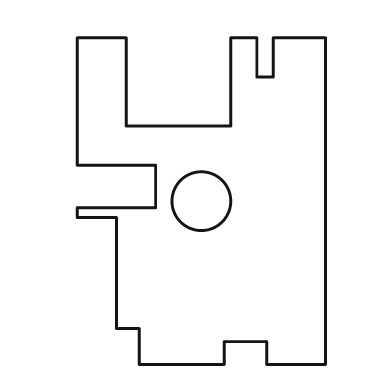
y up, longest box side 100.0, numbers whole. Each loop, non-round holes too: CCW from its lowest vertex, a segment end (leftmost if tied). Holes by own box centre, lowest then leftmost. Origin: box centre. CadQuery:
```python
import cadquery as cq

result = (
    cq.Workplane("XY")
    .moveTo(-19.0, -50.0)
    .lineTo(7.0, -50.0)
    .lineTo(7.0, -43.0)
    .lineTo(20.0, -43.0)
    .lineTo(20.0, -50.0)
    .lineTo(38.0, -50.0)
    .lineTo(38.0, 50.0)
    .lineTo(22.0, 50.0)
    .lineTo(22.0, 38.0)
    .lineTo(17.0, 38.0)
    .lineTo(17.0, 50.0)
    .lineTo(9.0, 50.0)
    .lineTo(9.0, 23.0)
    .lineTo(-23.0, 23.0)
    .lineTo(-23.0, 50.0)
    .lineTo(-38.0, 50.0)
    .lineTo(-38.0, 11.0)
    .lineTo(-14.0, 11.0)
    .lineTo(-14.0, -2.0)
    .lineTo(-38.0, -2.0)
    .lineTo(-38.0, -5.0)
    .lineTo(-26.0, -5.0)
    .lineTo(-26.0, -39.0)
    .lineTo(-19.0, -39.0)
    .close()
    .moveTo(0.0, 0.0)
    .circle(9.0)
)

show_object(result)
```